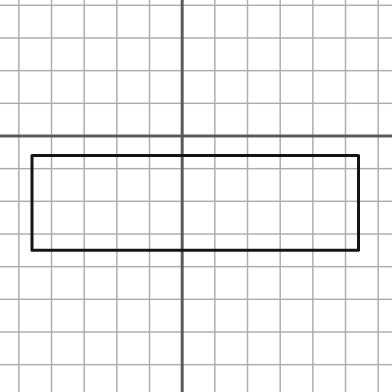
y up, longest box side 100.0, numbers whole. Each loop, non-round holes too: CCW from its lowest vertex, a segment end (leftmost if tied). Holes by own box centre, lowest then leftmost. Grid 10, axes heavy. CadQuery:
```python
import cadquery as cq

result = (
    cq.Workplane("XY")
    .moveTo(-46.0, -35.0)
    .lineTo(54.0, -35.0)
    .lineTo(54.0, -6.0)
    .lineTo(-46.0, -6.0)
    .close()
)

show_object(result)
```